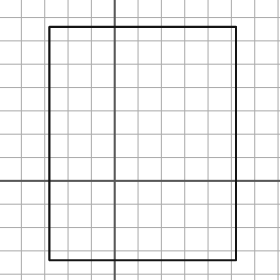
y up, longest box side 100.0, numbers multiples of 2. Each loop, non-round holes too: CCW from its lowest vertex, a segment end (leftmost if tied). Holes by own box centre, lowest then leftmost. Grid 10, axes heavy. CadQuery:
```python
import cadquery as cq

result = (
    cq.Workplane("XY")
    .moveTo(-28.0, -34.0)
    .lineTo(52.0, -34.0)
    .lineTo(52.0, 66.0)
    .lineTo(-28.0, 66.0)
    .close()
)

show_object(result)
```